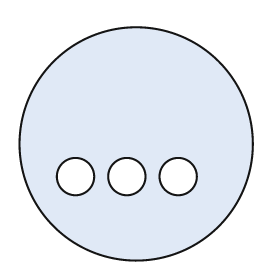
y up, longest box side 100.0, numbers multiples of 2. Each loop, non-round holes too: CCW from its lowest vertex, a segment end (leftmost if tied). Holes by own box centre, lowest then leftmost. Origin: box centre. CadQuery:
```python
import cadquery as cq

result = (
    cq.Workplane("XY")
    .moveTo(0.0, 0.0)
    .circle(50.0)
    .moveTo(-26.0, -14.0)
    .circle(8.0)
    .moveTo(-4.0, -14.0)
    .circle(8.0)
    .moveTo(18.0, -14.0)
    .circle(8.0)
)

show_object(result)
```